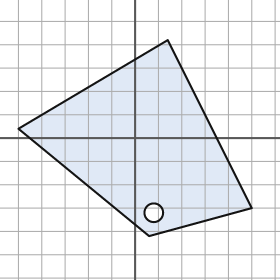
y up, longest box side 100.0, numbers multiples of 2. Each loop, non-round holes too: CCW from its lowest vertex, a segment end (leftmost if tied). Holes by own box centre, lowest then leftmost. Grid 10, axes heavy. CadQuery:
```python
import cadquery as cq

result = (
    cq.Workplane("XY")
    .moveTo(6.0, -42.0)
    .lineTo(50.0, -30.0)
    .lineTo(14.0, 42.0)
    .lineTo(-50.0, 4.0)
    .close()
    .moveTo(8.0, -32.0)
    .circle(4.0)
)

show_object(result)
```